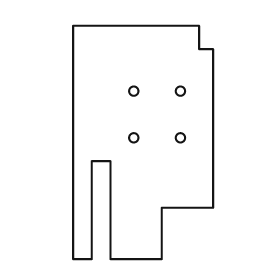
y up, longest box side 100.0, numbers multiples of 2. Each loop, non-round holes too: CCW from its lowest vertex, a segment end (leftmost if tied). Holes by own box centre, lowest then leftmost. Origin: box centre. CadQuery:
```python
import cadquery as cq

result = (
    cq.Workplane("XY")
    .moveTo(-30.0, -50.0)
    .lineTo(-22.0, -50.0)
    .lineTo(-22.0, -8.0)
    .lineTo(-14.0, -8.0)
    .lineTo(-14.0, -50.0)
    .lineTo(8.0, -50.0)
    .lineTo(8.0, -28.0)
    .lineTo(30.0, -28.0)
    .lineTo(30.0, 40.0)
    .lineTo(24.0, 40.0)
    .lineTo(24.0, 50.0)
    .lineTo(-30.0, 50.0)
    .close()
    .moveTo(-4.0, 2.0)
    .circle(2.0)
    .moveTo(16.0, 2.0)
    .circle(2.0)
    .moveTo(-4.0, 22.0)
    .circle(2.0)
    .moveTo(16.0, 22.0)
    .circle(2.0)
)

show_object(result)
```